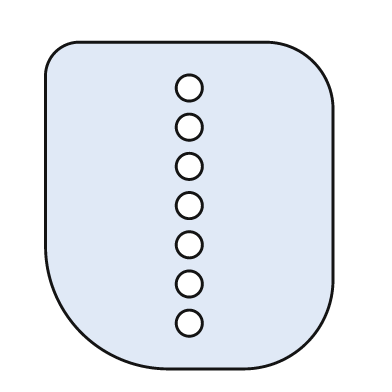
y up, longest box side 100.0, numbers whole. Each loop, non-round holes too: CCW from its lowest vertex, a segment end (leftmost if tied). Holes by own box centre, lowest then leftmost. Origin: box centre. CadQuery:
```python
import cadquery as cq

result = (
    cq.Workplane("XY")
    .moveTo(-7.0, -50.0)
    .lineTo(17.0, -50.0)
    .threePointArc((36.0, -42.0), (44.0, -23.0))
    .lineTo(44.0, 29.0)
    .threePointArc((38.0, 44.0), (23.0, 50.0))
    .lineTo(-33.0, 50.0)
    .threePointArc((-41.0, 47.0), (-44.0, 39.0))
    .lineTo(-44.0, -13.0)
    .threePointArc((-33.0, -39.0), (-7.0, -50.0))
    .close()
    .moveTo(0.0, -36.0)
    .circle(4.0)
    .moveTo(0.0, -24.0)
    .circle(4.0)
    .moveTo(0.0, -12.0)
    .circle(4.0)
    .moveTo(0.0, 0.0)
    .circle(4.0)
    .moveTo(0.0, 12.0)
    .circle(4.0)
    .moveTo(0.0, 24.0)
    .circle(4.0)
    .moveTo(0.0, 36.0)
    .circle(4.0)
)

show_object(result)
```